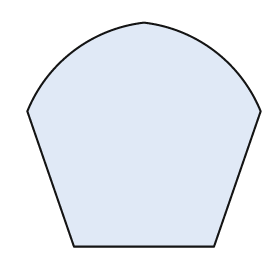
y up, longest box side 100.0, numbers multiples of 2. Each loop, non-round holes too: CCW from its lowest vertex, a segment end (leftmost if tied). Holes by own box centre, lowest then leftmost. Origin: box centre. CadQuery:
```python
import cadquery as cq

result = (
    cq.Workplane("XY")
    .moveTo(-30.0, -48.0)
    .lineTo(30.0, -48.0)
    .lineTo(50.0, 10.0)
    .threePointArc((30.0, 36.0), (0.0, 48.0))
    .threePointArc((-30.0, 36.0), (-50.0, 10.0))
    .close()
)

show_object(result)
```